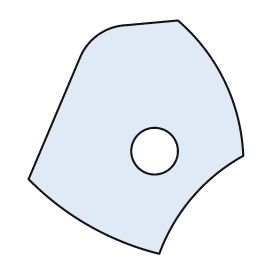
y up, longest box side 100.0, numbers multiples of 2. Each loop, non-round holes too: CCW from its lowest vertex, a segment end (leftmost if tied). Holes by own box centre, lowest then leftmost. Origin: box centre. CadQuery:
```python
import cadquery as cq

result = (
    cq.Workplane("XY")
    .moveTo(10.0, -50.0)
    .threePointArc((24.0, -26.0), (46.0, -8.0))
    .threePointArc((38.0, 24.0), (18.0, 50.0))
    .lineTo(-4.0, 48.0)
    .threePointArc((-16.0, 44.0), (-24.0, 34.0))
    .lineTo(-46.0, -18.0)
    .threePointArc((-20.0, -38.0), (10.0, -50.0))
    .close()
    .moveTo(8.0, -6.0)
    .circle(10.0)
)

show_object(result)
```